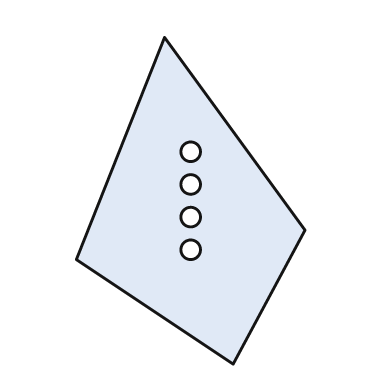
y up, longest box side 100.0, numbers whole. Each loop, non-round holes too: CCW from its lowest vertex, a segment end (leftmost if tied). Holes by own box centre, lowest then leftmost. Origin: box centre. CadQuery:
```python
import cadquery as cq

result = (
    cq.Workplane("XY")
    .moveTo(13.0, -50.0)
    .lineTo(35.0, -9.0)
    .lineTo(-8.0, 50.0)
    .lineTo(-35.0, -18.0)
    .close()
    .moveTo(0.0, -15.0)
    .circle(3.0)
    .moveTo(0.0, -5.0)
    .circle(3.0)
    .moveTo(0.0, 5.0)
    .circle(3.0)
    .moveTo(0.0, 15.0)
    .circle(3.0)
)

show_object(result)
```